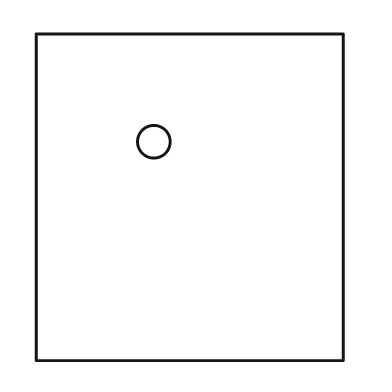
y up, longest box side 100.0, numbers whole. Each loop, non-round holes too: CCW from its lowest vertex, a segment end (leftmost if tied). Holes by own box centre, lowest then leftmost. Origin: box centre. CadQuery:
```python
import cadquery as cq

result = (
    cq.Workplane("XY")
    .moveTo(-47.0, -50.0)
    .lineTo(47.0, -50.0)
    .lineTo(47.0, 50.0)
    .lineTo(-47.0, 50.0)
    .close()
    .moveTo(-11.0, 17.0)
    .circle(5.0)
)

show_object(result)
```